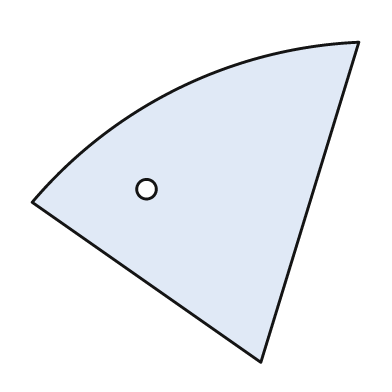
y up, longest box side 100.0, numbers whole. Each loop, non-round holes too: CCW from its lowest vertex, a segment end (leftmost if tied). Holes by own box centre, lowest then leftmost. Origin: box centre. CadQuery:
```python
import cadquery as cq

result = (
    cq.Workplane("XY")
    .moveTo(20.0, -49.0)
    .lineTo(50.0, 49.0)
    .threePointArc((-5.0, 35.0), (-50.0, 0.0))
    .close()
    .moveTo(-15.0, 4.0)
    .circle(3.0)
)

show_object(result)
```